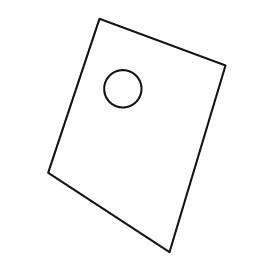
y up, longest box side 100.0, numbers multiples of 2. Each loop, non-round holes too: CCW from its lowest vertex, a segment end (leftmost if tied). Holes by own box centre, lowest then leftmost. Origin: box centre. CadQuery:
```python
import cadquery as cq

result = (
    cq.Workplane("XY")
    .moveTo(14.0, -50.0)
    .lineTo(38.0, 30.0)
    .lineTo(-16.0, 50.0)
    .lineTo(-38.0, -16.0)
    .close()
    .moveTo(-6.0, 20.0)
    .circle(8.0)
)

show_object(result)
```